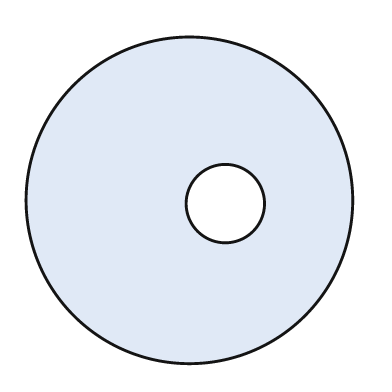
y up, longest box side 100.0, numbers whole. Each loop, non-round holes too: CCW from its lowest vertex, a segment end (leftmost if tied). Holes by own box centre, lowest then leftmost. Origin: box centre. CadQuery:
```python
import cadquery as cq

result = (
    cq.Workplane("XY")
    .moveTo(0.0, 0.0)
    .circle(50.0)
    .moveTo(11.0, -1.0)
    .circle(12.0)
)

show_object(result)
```